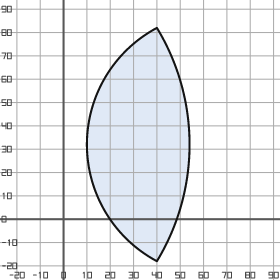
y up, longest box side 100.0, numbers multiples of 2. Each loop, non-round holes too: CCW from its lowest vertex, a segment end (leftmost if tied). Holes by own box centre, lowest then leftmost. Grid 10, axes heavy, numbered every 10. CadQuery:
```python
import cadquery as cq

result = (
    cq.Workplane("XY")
    .moveTo(40.0, -18.0)
    .threePointArc((54.0, 32.0), (40.0, 82.0))
    .threePointArc((10.0, 32.0), (40.0, -18.0))
    .close()
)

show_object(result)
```